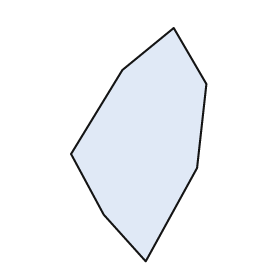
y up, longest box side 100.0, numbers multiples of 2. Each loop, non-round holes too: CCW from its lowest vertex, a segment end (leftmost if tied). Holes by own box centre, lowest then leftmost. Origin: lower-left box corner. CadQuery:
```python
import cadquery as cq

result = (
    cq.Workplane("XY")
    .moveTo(32.0, 0.0)
    .lineTo(54.0, 40.0)
    .lineTo(58.0, 76.0)
    .lineTo(44.0, 100.0)
    .lineTo(22.0, 82.0)
    .lineTo(0.0, 46.0)
    .lineTo(14.0, 20.0)
    .close()
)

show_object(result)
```